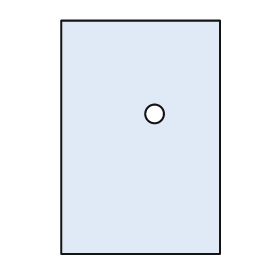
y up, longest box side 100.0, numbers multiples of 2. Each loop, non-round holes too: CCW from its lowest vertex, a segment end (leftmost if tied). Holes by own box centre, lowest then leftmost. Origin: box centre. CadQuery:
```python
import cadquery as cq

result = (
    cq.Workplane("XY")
    .moveTo(-34.0, -50.0)
    .lineTo(34.0, -50.0)
    .lineTo(34.0, 50.0)
    .lineTo(-34.0, 50.0)
    .close()
    .moveTo(6.0, 10.0)
    .circle(4.0)
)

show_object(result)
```